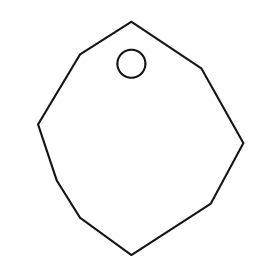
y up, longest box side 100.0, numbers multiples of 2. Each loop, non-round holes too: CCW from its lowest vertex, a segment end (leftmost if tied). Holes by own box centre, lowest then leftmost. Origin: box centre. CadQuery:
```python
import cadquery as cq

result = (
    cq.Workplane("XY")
    .moveTo(-4.0, -50.0)
    .lineTo(30.0, -28.0)
    .lineTo(44.0, -2.0)
    .lineTo(26.0, 30.0)
    .lineTo(-4.0, 50.0)
    .lineTo(-26.0, 36.0)
    .lineTo(-44.0, 6.0)
    .lineTo(-36.0, -18.0)
    .lineTo(-26.0, -34.0)
    .close()
    .moveTo(-4.0, 32.0)
    .circle(6.0)
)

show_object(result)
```